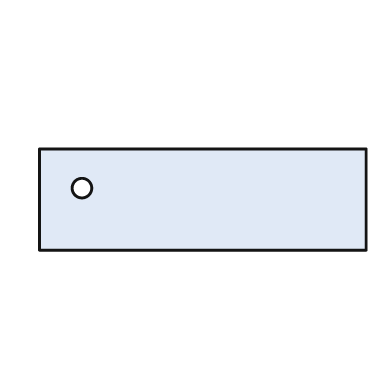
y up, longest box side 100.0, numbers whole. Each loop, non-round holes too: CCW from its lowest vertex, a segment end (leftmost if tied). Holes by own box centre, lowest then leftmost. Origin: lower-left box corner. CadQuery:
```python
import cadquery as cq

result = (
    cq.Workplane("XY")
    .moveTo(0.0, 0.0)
    .lineTo(100.0, 0.0)
    .lineTo(100.0, 31.0)
    .lineTo(0.0, 31.0)
    .close()
    .moveTo(13.0, 19.0)
    .circle(3.0)
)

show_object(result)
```